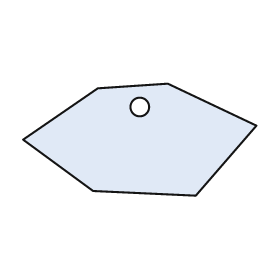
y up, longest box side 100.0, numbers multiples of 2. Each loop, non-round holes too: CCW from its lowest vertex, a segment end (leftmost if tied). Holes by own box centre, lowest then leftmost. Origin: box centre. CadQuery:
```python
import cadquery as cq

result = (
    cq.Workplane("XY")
    .moveTo(24.0, -24.0)
    .lineTo(50.0, 6.0)
    .lineTo(12.0, 24.0)
    .lineTo(-18.0, 22.0)
    .lineTo(-50.0, 0.0)
    .lineTo(-20.0, -22.0)
    .close()
    .moveTo(0.0, 14.0)
    .circle(4.0)
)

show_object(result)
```